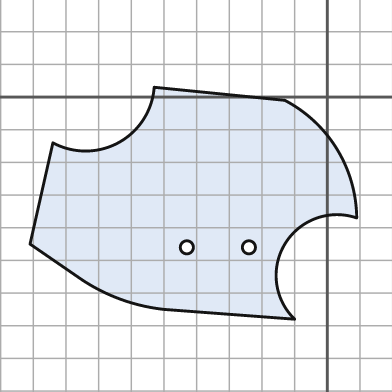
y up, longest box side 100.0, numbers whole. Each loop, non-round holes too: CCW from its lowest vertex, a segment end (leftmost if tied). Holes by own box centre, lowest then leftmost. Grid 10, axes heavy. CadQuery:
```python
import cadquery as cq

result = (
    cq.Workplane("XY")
    .moveTo(-10.0, -68.0)
    .threePointArc((-13.0, -45.0), (9.0, -37.0))
    .threePointArc((3.0, -16.0), (-13.0, -1.0))
    .lineTo(-53.0, 3.0)
    .threePointArc((-64.0, -14.0), (-84.0, -14.0))
    .lineTo(-91.0, -45.0)
    .lineTo(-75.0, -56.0)
    .threePointArc((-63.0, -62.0), (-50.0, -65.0))
    .close()
    .moveTo(-43.0, -46.0)
    .circle(2.0)
    .moveTo(-24.0, -46.0)
    .circle(2.0)
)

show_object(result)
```